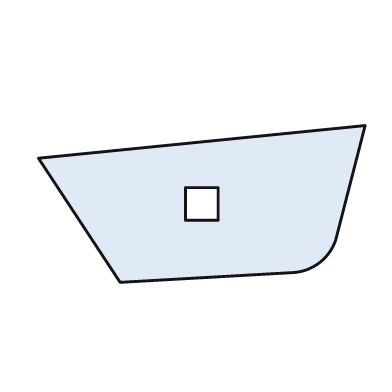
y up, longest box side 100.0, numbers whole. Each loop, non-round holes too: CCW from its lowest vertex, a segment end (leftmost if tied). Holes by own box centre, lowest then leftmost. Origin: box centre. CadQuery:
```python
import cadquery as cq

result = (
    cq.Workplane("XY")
    .moveTo(-25.0, -24.0)
    .lineTo(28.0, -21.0)
    .threePointArc((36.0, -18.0), (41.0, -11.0))
    .lineTo(50.0, 24.0)
    .lineTo(-50.0, 14.0)
    .close()
    .moveTo(-5.0, -5.0)
    .lineTo(5.0, -5.0)
    .lineTo(5.0, 5.0)
    .lineTo(-5.0, 5.0)
    .close()
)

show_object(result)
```